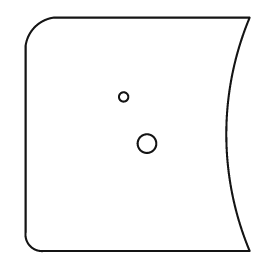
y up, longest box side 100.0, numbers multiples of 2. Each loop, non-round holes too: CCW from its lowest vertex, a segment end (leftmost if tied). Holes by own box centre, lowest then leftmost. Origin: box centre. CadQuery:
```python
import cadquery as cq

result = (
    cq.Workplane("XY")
    .moveTo(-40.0, -50.0)
    .lineTo(48.0, -50.0)
    .threePointArc((38.0, 0.0), (48.0, 50.0))
    .lineTo(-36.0, 50.0)
    .threePointArc((-44.0, 46.0), (-48.0, 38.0))
    .lineTo(-48.0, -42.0)
    .threePointArc((-46.0, -48.0), (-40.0, -50.0))
    .close()
    .moveTo(4.0, -4.0)
    .circle(4.0)
    .moveTo(-6.0, 16.0)
    .circle(2.0)
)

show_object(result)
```